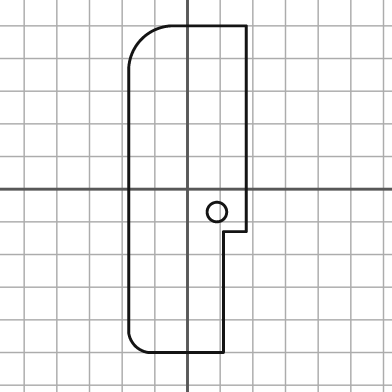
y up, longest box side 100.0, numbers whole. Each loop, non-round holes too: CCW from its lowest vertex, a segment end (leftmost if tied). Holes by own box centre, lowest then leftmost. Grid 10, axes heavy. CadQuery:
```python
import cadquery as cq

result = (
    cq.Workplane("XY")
    .moveTo(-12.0, -50.0)
    .lineTo(11.0, -50.0)
    .lineTo(11.0, -13.0)
    .lineTo(18.0, -13.0)
    .lineTo(18.0, 50.0)
    .lineTo(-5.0, 50.0)
    .threePointArc((-14.0, 46.0), (-18.0, 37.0))
    .lineTo(-18.0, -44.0)
    .threePointArc((-16.0, -48.0), (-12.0, -50.0))
    .close()
    .moveTo(9.0, -7.0)
    .circle(3.0)
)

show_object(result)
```